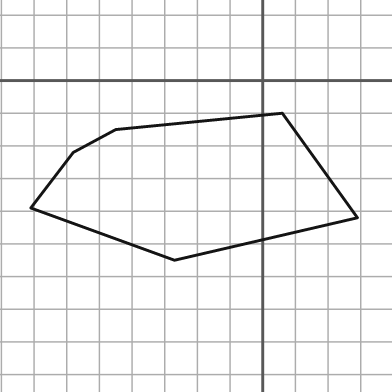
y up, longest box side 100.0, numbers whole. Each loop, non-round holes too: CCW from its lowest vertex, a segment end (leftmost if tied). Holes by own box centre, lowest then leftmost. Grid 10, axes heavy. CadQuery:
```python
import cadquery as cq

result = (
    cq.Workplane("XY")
    .moveTo(-27.0, -55.0)
    .lineTo(29.0, -42.0)
    .lineTo(6.0, -10.0)
    .lineTo(-45.0, -15.0)
    .lineTo(-58.0, -22.0)
    .lineTo(-71.0, -39.0)
    .close()
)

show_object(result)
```